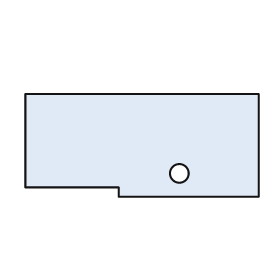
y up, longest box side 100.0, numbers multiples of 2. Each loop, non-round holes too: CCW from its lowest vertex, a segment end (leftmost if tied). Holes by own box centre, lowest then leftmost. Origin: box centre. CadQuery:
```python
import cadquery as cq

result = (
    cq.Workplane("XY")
    .moveTo(-10.0, -22.0)
    .lineTo(50.0, -22.0)
    .lineTo(50.0, 22.0)
    .lineTo(-50.0, 22.0)
    .lineTo(-50.0, -18.0)
    .lineTo(-10.0, -18.0)
    .close()
    .moveTo(16.0, -12.0)
    .circle(4.0)
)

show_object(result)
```